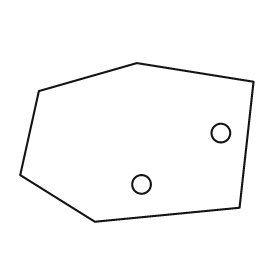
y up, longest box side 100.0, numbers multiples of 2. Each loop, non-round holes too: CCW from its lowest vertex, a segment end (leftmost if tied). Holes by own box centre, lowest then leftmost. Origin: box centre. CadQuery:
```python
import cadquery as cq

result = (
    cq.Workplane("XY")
    .moveTo(-18.0, -34.0)
    .lineTo(44.0, -28.0)
    .lineTo(50.0, 26.0)
    .lineTo(0.0, 34.0)
    .lineTo(-42.0, 22.0)
    .lineTo(-50.0, -14.0)
    .close()
    .moveTo(2.0, -18.0)
    .circle(4.0)
    .moveTo(36.0, 4.0)
    .circle(4.0)
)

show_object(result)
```